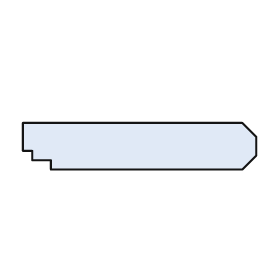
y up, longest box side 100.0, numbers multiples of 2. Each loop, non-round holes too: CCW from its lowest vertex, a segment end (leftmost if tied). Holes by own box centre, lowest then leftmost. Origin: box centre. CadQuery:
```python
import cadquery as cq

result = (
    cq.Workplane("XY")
    .moveTo(-38.0, -10.0)
    .lineTo(44.0, -10.0)
    .lineTo(50.0, -4.0)
    .lineTo(50.0, 4.0)
    .lineTo(44.0, 10.0)
    .lineTo(-50.0, 10.0)
    .lineTo(-50.0, -2.0)
    .lineTo(-46.0, -2.0)
    .lineTo(-46.0, -6.0)
    .lineTo(-38.0, -6.0)
    .close()
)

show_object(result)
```